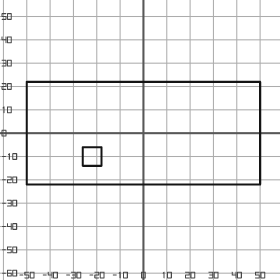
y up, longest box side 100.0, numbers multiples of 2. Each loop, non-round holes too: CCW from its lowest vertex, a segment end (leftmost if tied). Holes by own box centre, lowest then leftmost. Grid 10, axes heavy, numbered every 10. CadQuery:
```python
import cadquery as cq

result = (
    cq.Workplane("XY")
    .moveTo(-50.0, -22.0)
    .lineTo(50.0, -22.0)
    .lineTo(50.0, 22.0)
    .lineTo(-50.0, 22.0)
    .close()
    .moveTo(-26.0, -14.0)
    .lineTo(-18.0, -14.0)
    .lineTo(-18.0, -6.0)
    .lineTo(-26.0, -6.0)
    .close()
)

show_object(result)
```